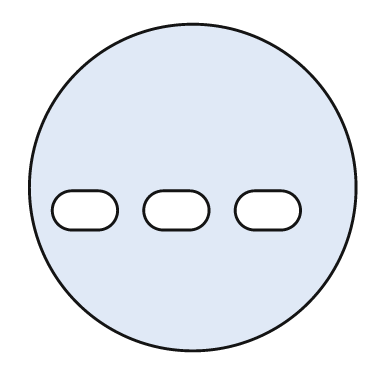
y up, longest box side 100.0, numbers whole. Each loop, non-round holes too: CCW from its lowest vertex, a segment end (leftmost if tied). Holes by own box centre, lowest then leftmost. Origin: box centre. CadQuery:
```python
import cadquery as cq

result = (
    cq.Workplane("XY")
    .moveTo(0.0, 0.0)
    .circle(50.0)
    .moveTo(-37.0, -13.0)
    .lineTo(-29.0, -13.0)
    .threePointArc((-23.0, -7.0), (-29.0, -1.0))
    .lineTo(-37.0, -1.0)
    .threePointArc((-43.0, -7.0), (-37.0, -13.0))
    .close()
    .moveTo(-9.0, -13.0)
    .lineTo(-1.0, -13.0)
    .threePointArc((5.0, -7.0), (-1.0, -1.0))
    .lineTo(-9.0, -1.0)
    .threePointArc((-15.0, -7.0), (-9.0, -13.0))
    .close()
    .moveTo(19.0, -13.0)
    .lineTo(27.0, -13.0)
    .threePointArc((33.0, -7.0), (27.0, -1.0))
    .lineTo(19.0, -1.0)
    .threePointArc((13.0, -7.0), (19.0, -13.0))
    .close()
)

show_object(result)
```